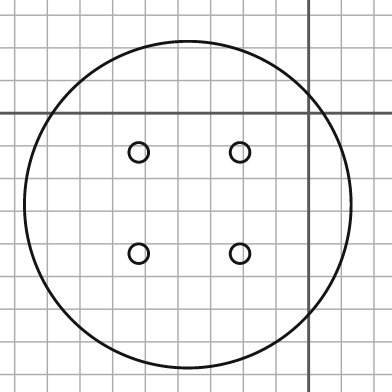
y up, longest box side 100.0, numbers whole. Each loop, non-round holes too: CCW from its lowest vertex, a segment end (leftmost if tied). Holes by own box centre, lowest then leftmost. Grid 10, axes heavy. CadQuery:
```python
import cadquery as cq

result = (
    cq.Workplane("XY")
    .moveTo(-37.0, -28.0)
    .circle(50.0)
    .moveTo(-52.0, -43.0)
    .circle(3.0)
    .moveTo(-21.0, -43.0)
    .circle(3.0)
    .moveTo(-52.0, -12.0)
    .circle(3.0)
    .moveTo(-21.0, -12.0)
    .circle(3.0)
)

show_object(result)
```